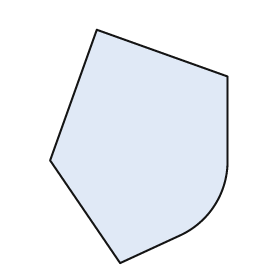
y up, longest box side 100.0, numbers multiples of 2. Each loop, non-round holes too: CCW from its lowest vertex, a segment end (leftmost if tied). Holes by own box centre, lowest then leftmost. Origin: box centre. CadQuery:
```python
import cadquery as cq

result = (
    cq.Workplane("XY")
    .moveTo(-8.0, -50.0)
    .lineTo(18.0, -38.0)
    .threePointArc((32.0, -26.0), (38.0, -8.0))
    .lineTo(38.0, 30.0)
    .lineTo(-18.0, 50.0)
    .lineTo(-38.0, -6.0)
    .close()
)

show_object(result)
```